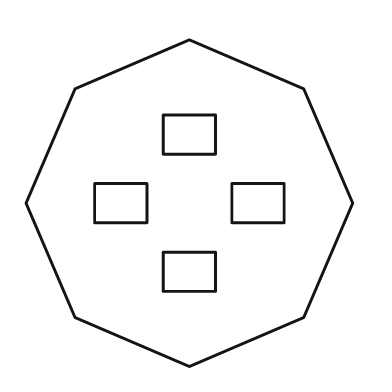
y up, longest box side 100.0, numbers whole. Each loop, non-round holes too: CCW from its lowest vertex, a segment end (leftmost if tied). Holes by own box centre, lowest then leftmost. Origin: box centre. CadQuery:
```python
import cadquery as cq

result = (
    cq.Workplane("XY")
    .moveTo(0.0, -50.0)
    .lineTo(35.0, -35.0)
    .lineTo(50.0, 0.0)
    .lineTo(35.0, 35.0)
    .lineTo(0.0, 50.0)
    .lineTo(-35.0, 35.0)
    .lineTo(-50.0, 0.0)
    .lineTo(-35.0, -35.0)
    .close()
    .moveTo(-8.0, -27.0)
    .lineTo(8.0, -27.0)
    .lineTo(8.0, -15.0)
    .lineTo(-8.0, -15.0)
    .close()
    .moveTo(-29.0, -6.0)
    .lineTo(-13.0, -6.0)
    .lineTo(-13.0, 6.0)
    .lineTo(-29.0, 6.0)
    .close()
    .moveTo(13.0, -6.0)
    .lineTo(29.0, -6.0)
    .lineTo(29.0, 6.0)
    .lineTo(13.0, 6.0)
    .close()
    .moveTo(-8.0, 15.0)
    .lineTo(8.0, 15.0)
    .lineTo(8.0, 27.0)
    .lineTo(-8.0, 27.0)
    .close()
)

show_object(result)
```